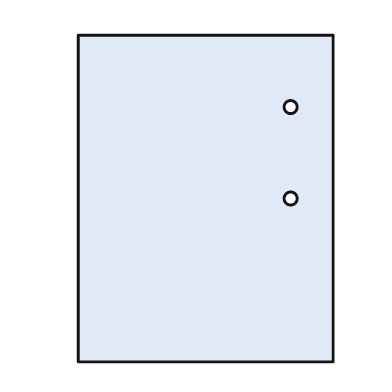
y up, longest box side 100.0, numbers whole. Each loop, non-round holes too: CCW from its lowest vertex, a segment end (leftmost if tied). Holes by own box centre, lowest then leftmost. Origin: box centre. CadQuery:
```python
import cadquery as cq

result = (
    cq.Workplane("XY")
    .moveTo(-39.0, -50.0)
    .lineTo(39.0, -50.0)
    .lineTo(39.0, 50.0)
    .lineTo(-39.0, 50.0)
    .close()
    .moveTo(26.0, 0.0)
    .circle(2.0)
    .moveTo(26.0, 28.0)
    .circle(2.0)
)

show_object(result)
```